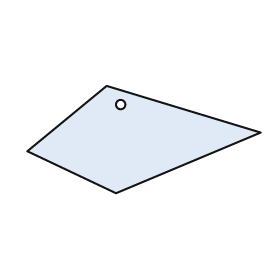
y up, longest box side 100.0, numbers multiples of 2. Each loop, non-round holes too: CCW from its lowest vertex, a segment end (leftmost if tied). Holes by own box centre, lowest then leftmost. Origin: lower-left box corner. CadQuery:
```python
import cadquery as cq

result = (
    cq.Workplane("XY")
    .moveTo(38.0, 0.0)
    .lineTo(100.0, 26.0)
    .lineTo(34.0, 46.0)
    .lineTo(0.0, 18.0)
    .close()
    .moveTo(40.0, 38.0)
    .circle(2.0)
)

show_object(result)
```